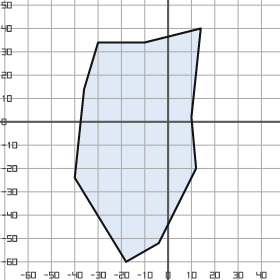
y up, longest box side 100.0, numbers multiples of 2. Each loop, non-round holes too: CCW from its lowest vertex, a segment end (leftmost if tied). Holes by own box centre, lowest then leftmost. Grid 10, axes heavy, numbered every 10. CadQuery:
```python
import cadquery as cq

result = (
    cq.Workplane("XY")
    .moveTo(-18.0, -60.0)
    .lineTo(-4.0, -52.0)
    .lineTo(12.0, -20.0)
    .lineTo(10.0, 2.0)
    .lineTo(14.0, 40.0)
    .lineTo(-10.0, 34.0)
    .lineTo(-30.0, 34.0)
    .lineTo(-36.0, 14.0)
    .lineTo(-40.0, -24.0)
    .close()
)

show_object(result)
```